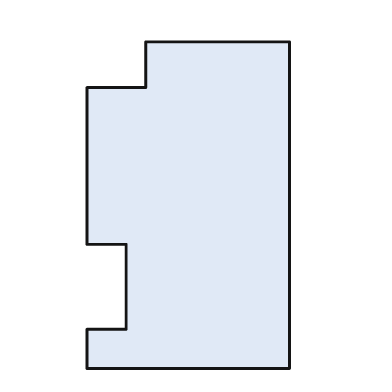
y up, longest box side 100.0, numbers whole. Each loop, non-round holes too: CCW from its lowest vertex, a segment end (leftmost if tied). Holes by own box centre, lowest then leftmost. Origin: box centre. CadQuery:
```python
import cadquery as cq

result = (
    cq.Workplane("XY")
    .moveTo(-31.0, -50.0)
    .lineTo(31.0, -50.0)
    .lineTo(31.0, 50.0)
    .lineTo(-13.0, 50.0)
    .lineTo(-13.0, 36.0)
    .lineTo(-31.0, 36.0)
    .lineTo(-31.0, -12.0)
    .lineTo(-19.0, -12.0)
    .lineTo(-19.0, -38.0)
    .lineTo(-31.0, -38.0)
    .close()
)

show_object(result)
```